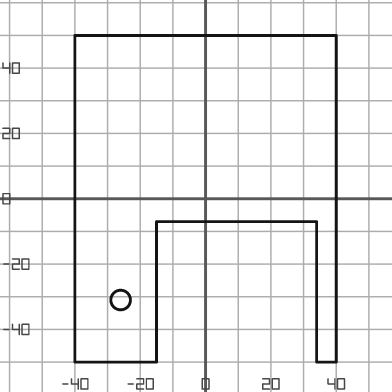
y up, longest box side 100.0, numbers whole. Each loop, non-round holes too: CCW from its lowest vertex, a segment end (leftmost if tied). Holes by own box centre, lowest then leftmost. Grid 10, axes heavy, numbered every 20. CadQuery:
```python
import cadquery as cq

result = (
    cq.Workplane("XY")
    .moveTo(-40.0, -50.0)
    .lineTo(-15.0, -50.0)
    .lineTo(-15.0, -7.0)
    .lineTo(34.0, -7.0)
    .lineTo(34.0, -50.0)
    .lineTo(40.0, -50.0)
    .lineTo(40.0, 50.0)
    .lineTo(-40.0, 50.0)
    .close()
    .moveTo(-26.0, -31.0)
    .circle(3.0)
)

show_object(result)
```